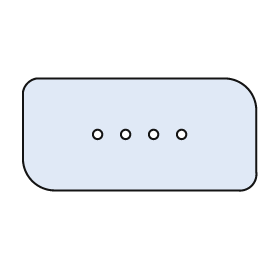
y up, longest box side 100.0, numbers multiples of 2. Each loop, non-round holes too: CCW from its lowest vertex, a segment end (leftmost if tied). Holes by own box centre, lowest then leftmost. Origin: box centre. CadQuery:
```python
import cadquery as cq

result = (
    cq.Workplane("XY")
    .moveTo(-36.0, -24.0)
    .lineTo(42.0, -24.0)
    .threePointArc((48.0, -22.0), (50.0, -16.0))
    .lineTo(50.0, 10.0)
    .threePointArc((46.0, 20.0), (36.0, 24.0))
    .lineTo(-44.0, 24.0)
    .threePointArc((-48.0, 22.0), (-50.0, 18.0))
    .lineTo(-50.0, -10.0)
    .threePointArc((-46.0, -20.0), (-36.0, -24.0))
    .close()
    .moveTo(-18.0, 0.0)
    .circle(2.0)
    .moveTo(-6.0, 0.0)
    .circle(2.0)
    .moveTo(6.0, 0.0)
    .circle(2.0)
    .moveTo(18.0, 0.0)
    .circle(2.0)
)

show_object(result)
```